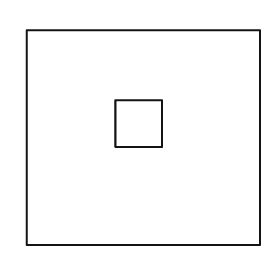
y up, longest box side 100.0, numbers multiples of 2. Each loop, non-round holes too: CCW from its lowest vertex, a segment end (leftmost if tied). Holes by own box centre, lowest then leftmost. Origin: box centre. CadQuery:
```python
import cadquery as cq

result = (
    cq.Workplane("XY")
    .moveTo(-50.0, -46.0)
    .lineTo(50.0, -46.0)
    .lineTo(50.0, 46.0)
    .lineTo(-50.0, 46.0)
    .close()
    .moveTo(-12.0, -4.0)
    .lineTo(8.0, -4.0)
    .lineTo(8.0, 16.0)
    .lineTo(-12.0, 16.0)
    .close()
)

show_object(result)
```